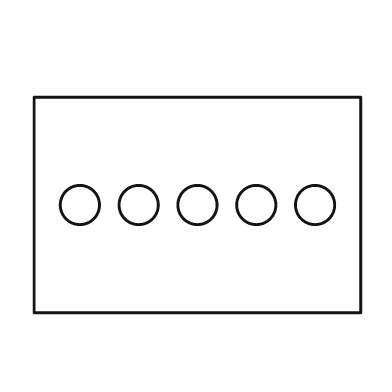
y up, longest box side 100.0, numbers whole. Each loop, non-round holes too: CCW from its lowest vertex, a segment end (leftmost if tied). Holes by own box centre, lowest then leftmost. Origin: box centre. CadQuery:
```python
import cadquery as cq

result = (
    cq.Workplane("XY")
    .moveTo(-50.0, -33.0)
    .lineTo(50.0, -33.0)
    .lineTo(50.0, 33.0)
    .lineTo(-50.0, 33.0)
    .close()
    .moveTo(-36.0, 0.0)
    .circle(6.0)
    .moveTo(-18.0, 0.0)
    .circle(6.0)
    .moveTo(0.0, 0.0)
    .circle(6.0)
    .moveTo(18.0, 0.0)
    .circle(6.0)
    .moveTo(36.0, 0.0)
    .circle(6.0)
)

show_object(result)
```